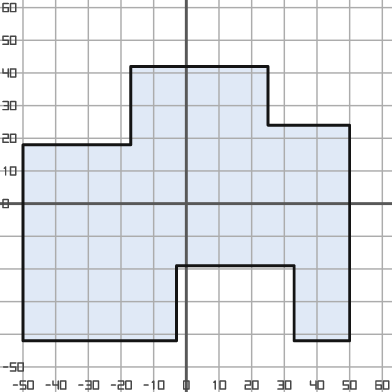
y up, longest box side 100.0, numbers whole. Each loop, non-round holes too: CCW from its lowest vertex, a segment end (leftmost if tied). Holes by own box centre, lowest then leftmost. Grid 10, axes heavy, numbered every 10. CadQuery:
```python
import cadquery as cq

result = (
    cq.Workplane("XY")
    .moveTo(-50.0, -42.0)
    .lineTo(-3.0, -42.0)
    .lineTo(-3.0, -19.0)
    .lineTo(33.0, -19.0)
    .lineTo(33.0, -42.0)
    .lineTo(50.0, -42.0)
    .lineTo(50.0, 24.0)
    .lineTo(25.0, 24.0)
    .lineTo(25.0, 42.0)
    .lineTo(-17.0, 42.0)
    .lineTo(-17.0, 18.0)
    .lineTo(-50.0, 18.0)
    .close()
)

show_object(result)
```